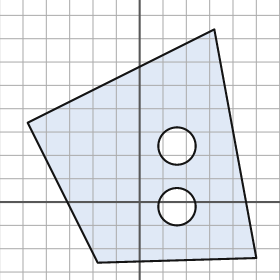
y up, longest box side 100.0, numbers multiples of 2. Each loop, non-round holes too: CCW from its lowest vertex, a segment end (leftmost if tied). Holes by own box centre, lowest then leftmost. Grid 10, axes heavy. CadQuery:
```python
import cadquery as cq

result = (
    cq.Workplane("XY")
    .moveTo(-18.0, -26.0)
    .lineTo(50.0, -24.0)
    .lineTo(32.0, 74.0)
    .lineTo(-48.0, 34.0)
    .close()
    .moveTo(16.0, -2.0)
    .circle(8.0)
    .moveTo(16.0, 24.0)
    .circle(8.0)
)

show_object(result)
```